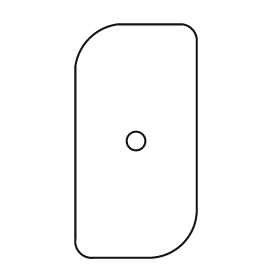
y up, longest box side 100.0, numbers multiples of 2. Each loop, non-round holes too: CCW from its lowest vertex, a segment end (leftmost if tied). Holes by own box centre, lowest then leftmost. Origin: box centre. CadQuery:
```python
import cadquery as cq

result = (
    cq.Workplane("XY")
    .moveTo(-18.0, -50.0)
    .lineTo(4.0, -50.0)
    .threePointArc((20.0, -44.0), (26.0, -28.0))
    .lineTo(26.0, 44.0)
    .threePointArc((24.0, 48.0), (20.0, 50.0))
    .lineTo(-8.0, 50.0)
    .threePointArc((-20.0, 44.0), (-26.0, 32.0))
    .lineTo(-26.0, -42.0)
    .threePointArc((-24.0, -48.0), (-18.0, -50.0))
    .close()
    .moveTo(0.0, 0.0)
    .circle(4.0)
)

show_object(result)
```